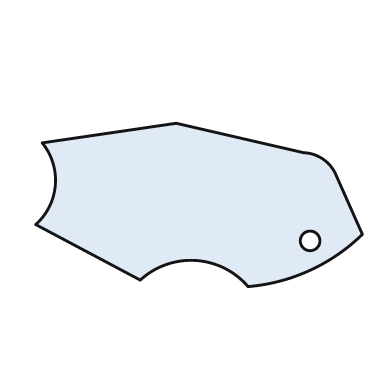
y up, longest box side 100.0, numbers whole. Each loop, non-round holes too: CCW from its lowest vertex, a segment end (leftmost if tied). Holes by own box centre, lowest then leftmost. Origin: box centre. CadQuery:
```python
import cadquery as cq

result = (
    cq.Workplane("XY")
    .moveTo(15.0, -25.0)
    .threePointArc((34.0, -20.0), (50.0, -9.0))
    .lineTo(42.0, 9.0)
    .threePointArc((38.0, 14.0), (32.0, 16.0))
    .lineTo(-7.0, 25.0)
    .lineTo(-48.0, 19.0)
    .threePointArc((-44.0, 6.0), (-50.0, -6.0))
    .lineTo(-18.0, -23.0)
    .threePointArc((-1.0, -17.0), (15.0, -25.0))
    .close()
    .moveTo(34.0, -11.0)
    .circle(3.0)
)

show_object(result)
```